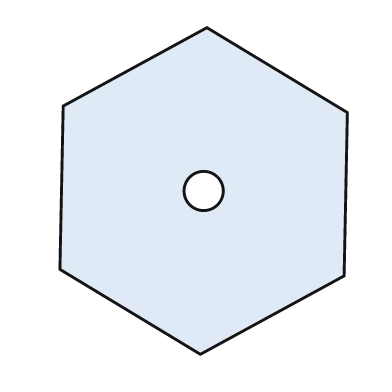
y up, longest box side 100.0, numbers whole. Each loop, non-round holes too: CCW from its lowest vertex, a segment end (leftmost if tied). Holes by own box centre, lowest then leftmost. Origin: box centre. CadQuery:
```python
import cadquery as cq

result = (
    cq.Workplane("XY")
    .moveTo(-1.0, -50.0)
    .lineTo(43.0, -26.0)
    .lineTo(44.0, 24.0)
    .lineTo(1.0, 50.0)
    .lineTo(-43.0, 26.0)
    .lineTo(-44.0, -24.0)
    .close()
    .moveTo(0.0, 0.0)
    .circle(6.0)
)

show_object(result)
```